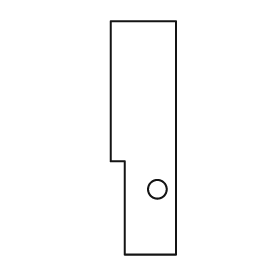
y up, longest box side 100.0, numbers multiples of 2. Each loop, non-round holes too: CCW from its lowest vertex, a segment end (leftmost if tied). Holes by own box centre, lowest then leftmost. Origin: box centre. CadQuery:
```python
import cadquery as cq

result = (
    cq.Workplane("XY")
    .moveTo(-8.0, -50.0)
    .lineTo(14.0, -50.0)
    .lineTo(14.0, 50.0)
    .lineTo(-14.0, 50.0)
    .lineTo(-14.0, -10.0)
    .lineTo(-8.0, -10.0)
    .close()
    .moveTo(6.0, -22.0)
    .circle(4.0)
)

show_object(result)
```